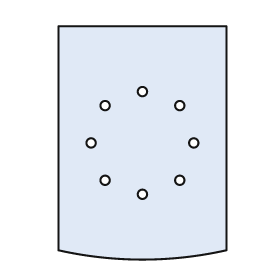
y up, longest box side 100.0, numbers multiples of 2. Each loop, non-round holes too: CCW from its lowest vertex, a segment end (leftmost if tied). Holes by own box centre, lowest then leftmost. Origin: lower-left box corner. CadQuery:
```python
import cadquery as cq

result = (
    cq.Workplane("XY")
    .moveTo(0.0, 4.0)
    .threePointArc((36.0, 0.0), (72.0, 4.0))
    .lineTo(72.0, 100.0)
    .lineTo(0.0, 100.0)
    .close()
    .moveTo(36.0, 28.0)
    .circle(2.0)
    .moveTo(20.0, 34.0)
    .circle(2.0)
    .moveTo(52.0, 34.0)
    .circle(2.0)
    .moveTo(14.0, 50.0)
    .circle(2.0)
    .moveTo(58.0, 50.0)
    .circle(2.0)
    .moveTo(20.0, 66.0)
    .circle(2.0)
    .moveTo(52.0, 66.0)
    .circle(2.0)
    .moveTo(36.0, 72.0)
    .circle(2.0)
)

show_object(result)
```